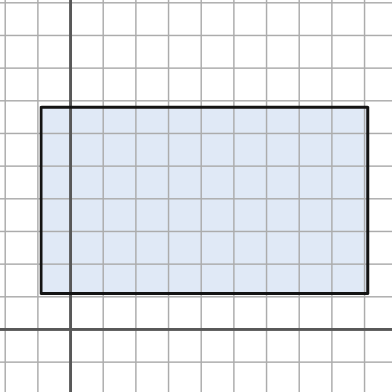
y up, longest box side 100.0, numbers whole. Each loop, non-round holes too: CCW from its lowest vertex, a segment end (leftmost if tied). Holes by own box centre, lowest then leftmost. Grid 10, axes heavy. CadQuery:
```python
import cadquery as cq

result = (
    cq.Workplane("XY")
    .moveTo(-9.0, 11.0)
    .lineTo(91.0, 11.0)
    .lineTo(91.0, 68.0)
    .lineTo(-9.0, 68.0)
    .close()
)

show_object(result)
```